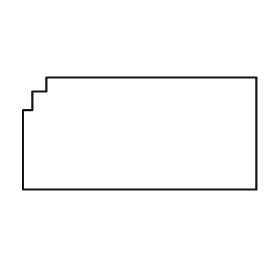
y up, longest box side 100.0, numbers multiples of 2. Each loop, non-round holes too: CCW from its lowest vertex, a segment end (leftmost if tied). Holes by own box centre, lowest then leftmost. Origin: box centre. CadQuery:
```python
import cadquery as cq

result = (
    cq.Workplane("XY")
    .moveTo(-50.0, -24.0)
    .lineTo(50.0, -24.0)
    .lineTo(50.0, 24.0)
    .lineTo(-40.0, 24.0)
    .lineTo(-40.0, 18.0)
    .lineTo(-46.0, 18.0)
    .lineTo(-46.0, 10.0)
    .lineTo(-50.0, 10.0)
    .close()
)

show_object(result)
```